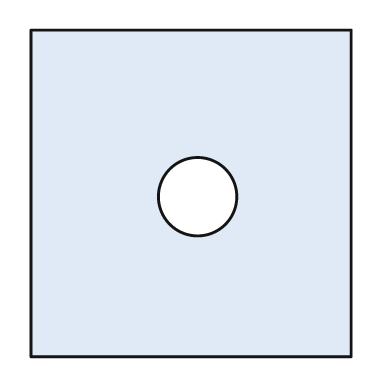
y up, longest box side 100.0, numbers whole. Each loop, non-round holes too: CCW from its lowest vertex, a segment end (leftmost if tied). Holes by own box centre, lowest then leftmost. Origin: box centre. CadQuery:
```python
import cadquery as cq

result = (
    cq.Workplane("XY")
    .moveTo(-49.0, -50.0)
    .lineTo(49.0, -50.0)
    .lineTo(49.0, 50.0)
    .lineTo(-49.0, 50.0)
    .close()
    .moveTo(2.0, -1.0)
    .circle(12.0)
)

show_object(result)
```